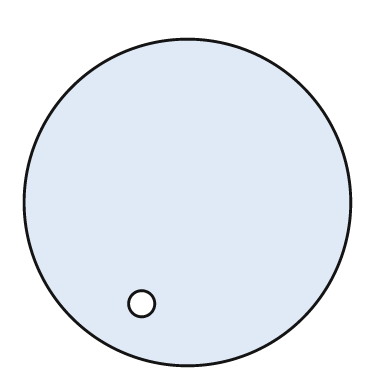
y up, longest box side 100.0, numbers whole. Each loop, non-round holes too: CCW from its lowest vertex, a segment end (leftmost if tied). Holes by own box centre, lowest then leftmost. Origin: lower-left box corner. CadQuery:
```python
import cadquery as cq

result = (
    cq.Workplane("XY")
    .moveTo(50.0, 50.0)
    .circle(50.0)
    .moveTo(36.0, 19.0)
    .circle(4.0)
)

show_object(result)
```